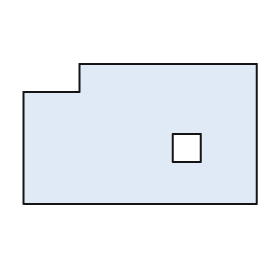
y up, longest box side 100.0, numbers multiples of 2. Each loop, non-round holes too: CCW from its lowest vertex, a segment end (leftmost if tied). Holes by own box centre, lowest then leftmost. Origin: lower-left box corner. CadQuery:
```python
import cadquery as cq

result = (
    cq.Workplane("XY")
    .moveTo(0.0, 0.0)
    .lineTo(100.0, 0.0)
    .lineTo(100.0, 60.0)
    .lineTo(24.0, 60.0)
    .lineTo(24.0, 48.0)
    .lineTo(0.0, 48.0)
    .close()
    .moveTo(64.0, 18.0)
    .lineTo(76.0, 18.0)
    .lineTo(76.0, 30.0)
    .lineTo(64.0, 30.0)
    .close()
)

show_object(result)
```